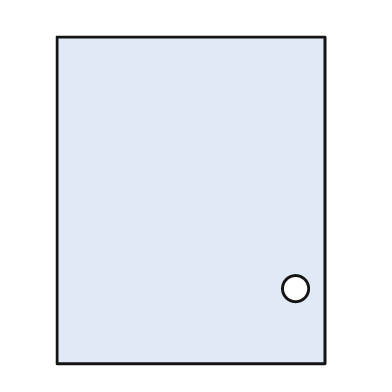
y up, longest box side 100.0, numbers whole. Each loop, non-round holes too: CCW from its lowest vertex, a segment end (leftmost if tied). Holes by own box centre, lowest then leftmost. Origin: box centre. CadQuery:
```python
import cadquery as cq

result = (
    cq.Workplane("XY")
    .moveTo(-41.0, -50.0)
    .lineTo(41.0, -50.0)
    .lineTo(41.0, 50.0)
    .lineTo(-41.0, 50.0)
    .close()
    .moveTo(32.0, -27.0)
    .circle(4.0)
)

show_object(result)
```